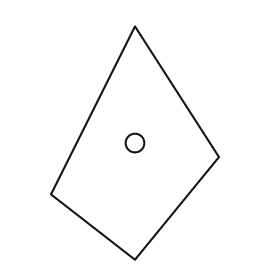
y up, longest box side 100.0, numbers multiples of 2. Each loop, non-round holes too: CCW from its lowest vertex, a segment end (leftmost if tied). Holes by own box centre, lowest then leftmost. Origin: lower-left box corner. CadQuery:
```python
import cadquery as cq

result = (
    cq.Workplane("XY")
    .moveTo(36.0, 0.0)
    .lineTo(72.0, 44.0)
    .lineTo(36.0, 100.0)
    .lineTo(0.0, 28.0)
    .close()
    .moveTo(36.0, 50.0)
    .circle(4.0)
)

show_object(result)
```